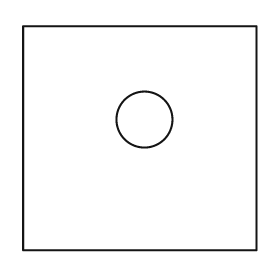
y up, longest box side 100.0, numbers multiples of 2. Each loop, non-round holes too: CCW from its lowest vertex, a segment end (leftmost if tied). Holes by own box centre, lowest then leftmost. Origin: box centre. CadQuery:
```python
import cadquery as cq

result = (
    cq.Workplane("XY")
    .moveTo(-50.0, -48.0)
    .lineTo(50.0, -48.0)
    .lineTo(50.0, 48.0)
    .lineTo(-50.0, 48.0)
    .close()
    .moveTo(2.0, 8.0)
    .circle(12.0)
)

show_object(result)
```